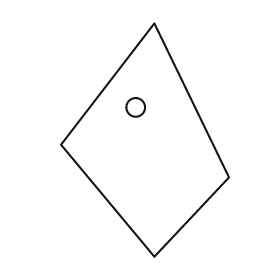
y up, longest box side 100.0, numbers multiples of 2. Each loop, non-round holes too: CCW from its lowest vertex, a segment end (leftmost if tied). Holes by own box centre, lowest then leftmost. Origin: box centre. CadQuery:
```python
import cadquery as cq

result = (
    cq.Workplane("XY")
    .moveTo(4.0, -50.0)
    .lineTo(36.0, -16.0)
    .lineTo(4.0, 50.0)
    .lineTo(-36.0, -2.0)
    .close()
    .moveTo(-4.0, 14.0)
    .circle(4.0)
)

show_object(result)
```